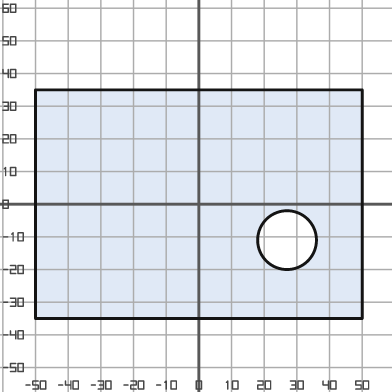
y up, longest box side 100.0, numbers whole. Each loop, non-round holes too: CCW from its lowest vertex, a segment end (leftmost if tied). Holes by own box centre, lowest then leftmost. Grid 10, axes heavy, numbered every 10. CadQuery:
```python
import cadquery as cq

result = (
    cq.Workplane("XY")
    .moveTo(-50.0, -35.0)
    .lineTo(50.0, -35.0)
    .lineTo(50.0, 35.0)
    .lineTo(-50.0, 35.0)
    .close()
    .moveTo(27.0, -11.0)
    .circle(9.0)
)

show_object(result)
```